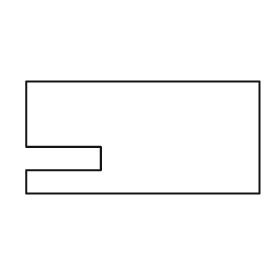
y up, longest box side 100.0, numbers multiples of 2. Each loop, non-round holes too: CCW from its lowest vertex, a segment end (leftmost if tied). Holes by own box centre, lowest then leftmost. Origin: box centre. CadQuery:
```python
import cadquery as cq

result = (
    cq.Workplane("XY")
    .moveTo(-50.0, -24.0)
    .lineTo(50.0, -24.0)
    .lineTo(50.0, 24.0)
    .lineTo(-50.0, 24.0)
    .lineTo(-50.0, -4.0)
    .lineTo(-18.0, -4.0)
    .lineTo(-18.0, -14.0)
    .lineTo(-50.0, -14.0)
    .close()
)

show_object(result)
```